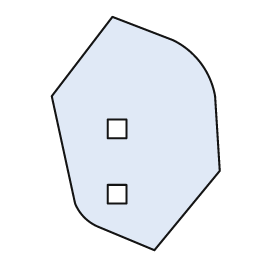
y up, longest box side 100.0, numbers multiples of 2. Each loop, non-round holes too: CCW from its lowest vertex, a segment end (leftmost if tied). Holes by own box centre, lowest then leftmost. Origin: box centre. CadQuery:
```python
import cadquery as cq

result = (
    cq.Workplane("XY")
    .moveTo(8.0, -50.0)
    .lineTo(36.0, -16.0)
    .lineTo(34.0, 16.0)
    .threePointArc((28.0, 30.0), (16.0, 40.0))
    .lineTo(-10.0, 50.0)
    .lineTo(-36.0, 16.0)
    .lineTo(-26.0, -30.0)
    .threePointArc((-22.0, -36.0), (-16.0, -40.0))
    .close()
    .moveTo(-12.0, -30.0)
    .lineTo(-4.0, -30.0)
    .lineTo(-4.0, -22.0)
    .lineTo(-12.0, -22.0)
    .close()
    .moveTo(-12.0, -2.0)
    .lineTo(-4.0, -2.0)
    .lineTo(-4.0, 6.0)
    .lineTo(-12.0, 6.0)
    .close()
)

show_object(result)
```